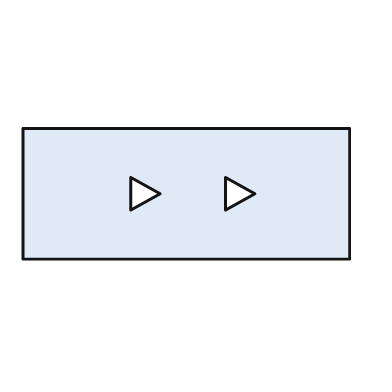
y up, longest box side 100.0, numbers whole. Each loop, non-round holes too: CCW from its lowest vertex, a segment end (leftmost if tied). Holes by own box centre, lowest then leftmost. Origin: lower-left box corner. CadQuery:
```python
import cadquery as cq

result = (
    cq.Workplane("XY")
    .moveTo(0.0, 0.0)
    .lineTo(100.0, 0.0)
    .lineTo(100.0, 40.0)
    .lineTo(0.0, 40.0)
    .close()
    .moveTo(33.0, 15.0)
    .lineTo(42.0, 20.0)
    .lineTo(33.0, 25.0)
    .close()
    .moveTo(62.0, 15.0)
    .lineTo(71.0, 20.0)
    .lineTo(62.0, 25.0)
    .close()
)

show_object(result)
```